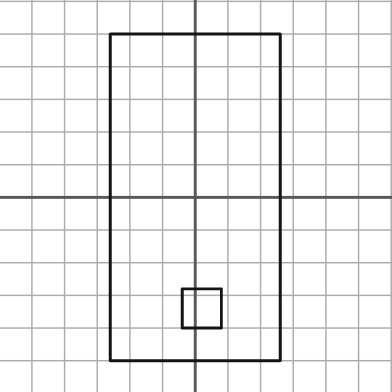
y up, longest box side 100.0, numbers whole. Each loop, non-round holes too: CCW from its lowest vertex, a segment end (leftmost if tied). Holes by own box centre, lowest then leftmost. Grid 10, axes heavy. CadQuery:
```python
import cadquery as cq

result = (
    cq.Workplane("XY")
    .moveTo(-26.0, -50.0)
    .lineTo(26.0, -50.0)
    .lineTo(26.0, 50.0)
    .lineTo(-26.0, 50.0)
    .close()
    .moveTo(-4.0, -40.0)
    .lineTo(8.0, -40.0)
    .lineTo(8.0, -28.0)
    .lineTo(-4.0, -28.0)
    .close()
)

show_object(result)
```